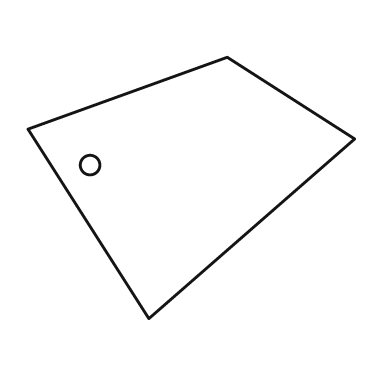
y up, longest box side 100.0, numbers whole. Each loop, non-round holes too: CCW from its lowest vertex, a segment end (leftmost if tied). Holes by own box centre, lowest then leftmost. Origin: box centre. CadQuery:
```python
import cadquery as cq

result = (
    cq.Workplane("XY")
    .moveTo(-13.0, -40.0)
    .lineTo(50.0, 15.0)
    .lineTo(11.0, 40.0)
    .lineTo(-50.0, 18.0)
    .close()
    .moveTo(-31.0, 7.0)
    .circle(3.0)
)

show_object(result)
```